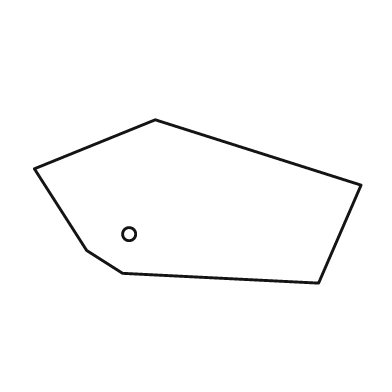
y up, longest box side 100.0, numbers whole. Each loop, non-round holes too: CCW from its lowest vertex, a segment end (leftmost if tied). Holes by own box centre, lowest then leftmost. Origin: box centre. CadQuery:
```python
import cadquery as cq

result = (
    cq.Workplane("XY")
    .moveTo(37.0, -25.0)
    .lineTo(50.0, 5.0)
    .lineTo(-13.0, 25.0)
    .lineTo(-50.0, 10.0)
    .lineTo(-34.0, -15.0)
    .lineTo(-23.0, -22.0)
    .close()
    .moveTo(-21.0, -10.0)
    .circle(2.0)
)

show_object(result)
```